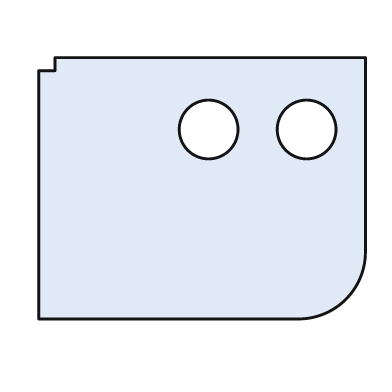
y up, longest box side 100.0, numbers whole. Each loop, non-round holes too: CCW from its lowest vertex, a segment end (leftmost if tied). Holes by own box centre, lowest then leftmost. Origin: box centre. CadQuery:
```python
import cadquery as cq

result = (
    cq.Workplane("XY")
    .moveTo(-50.0, -40.0)
    .lineTo(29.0, -40.0)
    .threePointArc((44.0, -34.0), (50.0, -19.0))
    .lineTo(50.0, 40.0)
    .lineTo(-45.0, 40.0)
    .lineTo(-45.0, 36.0)
    .lineTo(-50.0, 36.0)
    .close()
    .moveTo(2.0, 18.0)
    .circle(9.0)
    .moveTo(32.0, 18.0)
    .circle(9.0)
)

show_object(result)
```